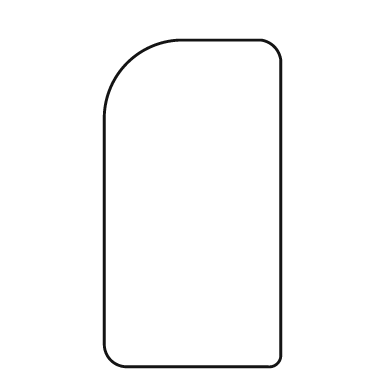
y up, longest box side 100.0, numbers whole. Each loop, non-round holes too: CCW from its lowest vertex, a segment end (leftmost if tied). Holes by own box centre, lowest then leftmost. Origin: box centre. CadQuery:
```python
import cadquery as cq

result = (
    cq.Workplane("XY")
    .moveTo(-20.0, -50.0)
    .lineTo(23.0, -50.0)
    .threePointArc((26.0, -49.0), (27.0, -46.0))
    .lineTo(27.0, 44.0)
    .threePointArc((25.0, 48.0), (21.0, 50.0))
    .lineTo(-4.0, 50.0)
    .threePointArc((-20.0, 43.0), (-27.0, 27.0))
    .lineTo(-27.0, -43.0)
    .threePointArc((-25.0, -48.0), (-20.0, -50.0))
    .close()
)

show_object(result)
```